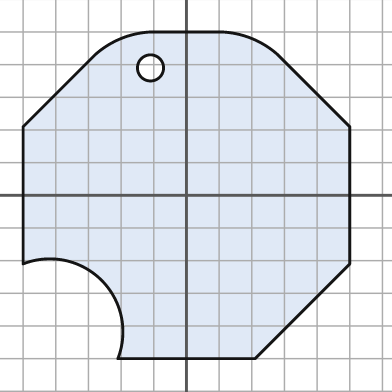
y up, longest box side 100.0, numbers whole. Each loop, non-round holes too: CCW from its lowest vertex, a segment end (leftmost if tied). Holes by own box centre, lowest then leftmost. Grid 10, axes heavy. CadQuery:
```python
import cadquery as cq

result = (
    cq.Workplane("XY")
    .moveTo(-21.0, -50.0)
    .lineTo(21.0, -50.0)
    .lineTo(50.0, -21.0)
    .lineTo(50.0, 21.0)
    .lineTo(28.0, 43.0)
    .threePointArc((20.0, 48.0), (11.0, 50.0))
    .lineTo(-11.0, 50.0)
    .threePointArc((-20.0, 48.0), (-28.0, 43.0))
    .lineTo(-50.0, 21.0)
    .lineTo(-50.0, -21.0)
    .threePointArc((-26.0, -26.0), (-21.0, -50.0))
    .close()
    .moveTo(-11.0, 39.0)
    .circle(4.0)
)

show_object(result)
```